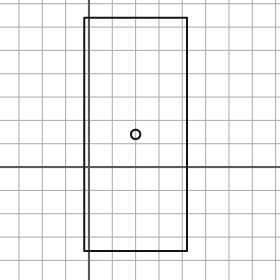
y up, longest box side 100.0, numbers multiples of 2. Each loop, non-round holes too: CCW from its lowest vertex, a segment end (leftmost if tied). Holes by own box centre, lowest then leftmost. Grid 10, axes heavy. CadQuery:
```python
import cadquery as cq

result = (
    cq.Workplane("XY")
    .moveTo(-2.0, -36.0)
    .lineTo(42.0, -36.0)
    .lineTo(42.0, 64.0)
    .lineTo(-2.0, 64.0)
    .close()
    .moveTo(20.0, 14.0)
    .circle(2.0)
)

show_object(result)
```